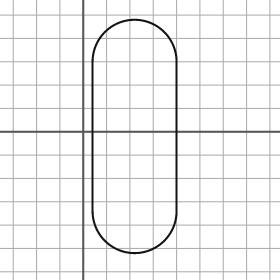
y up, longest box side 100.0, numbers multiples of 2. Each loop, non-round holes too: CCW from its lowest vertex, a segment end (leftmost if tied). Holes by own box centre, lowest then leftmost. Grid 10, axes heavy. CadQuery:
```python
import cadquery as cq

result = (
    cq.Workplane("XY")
    .moveTo(4.0, -34.0)
    .threePointArc((22.0, -52.0), (40.0, -34.0))
    .lineTo(40.0, 30.0)
    .threePointArc((22.0, 48.0), (4.0, 30.0))
    .close()
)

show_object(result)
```